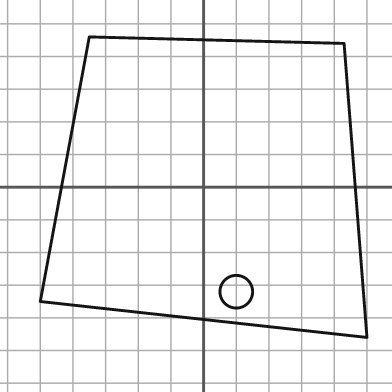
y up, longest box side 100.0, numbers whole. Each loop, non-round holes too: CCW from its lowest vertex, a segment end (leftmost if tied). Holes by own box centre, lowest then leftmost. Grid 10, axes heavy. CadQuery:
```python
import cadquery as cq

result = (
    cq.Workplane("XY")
    .moveTo(50.0, -46.0)
    .lineTo(43.0, 44.0)
    .lineTo(-35.0, 46.0)
    .lineTo(-50.0, -35.0)
    .close()
    .moveTo(10.0, -32.0)
    .circle(5.0)
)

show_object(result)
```